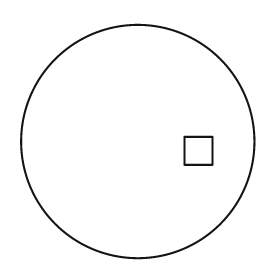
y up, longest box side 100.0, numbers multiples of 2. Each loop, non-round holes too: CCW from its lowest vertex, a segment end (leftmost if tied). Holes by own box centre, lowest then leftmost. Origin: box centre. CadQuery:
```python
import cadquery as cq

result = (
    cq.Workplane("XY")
    .moveTo(0.0, 0.0)
    .circle(50.0)
    .moveTo(20.0, -10.0)
    .lineTo(32.0, -10.0)
    .lineTo(32.0, 2.0)
    .lineTo(20.0, 2.0)
    .close()
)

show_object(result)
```